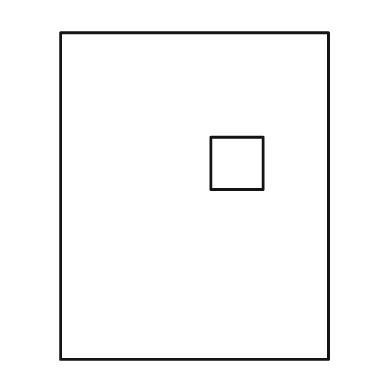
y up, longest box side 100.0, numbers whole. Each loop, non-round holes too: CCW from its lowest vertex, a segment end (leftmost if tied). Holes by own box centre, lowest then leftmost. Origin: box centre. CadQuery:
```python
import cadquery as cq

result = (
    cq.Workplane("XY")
    .moveTo(-41.0, -50.0)
    .lineTo(41.0, -50.0)
    .lineTo(41.0, 50.0)
    .lineTo(-41.0, 50.0)
    .close()
    .moveTo(5.0, 2.0)
    .lineTo(21.0, 2.0)
    .lineTo(21.0, 18.0)
    .lineTo(5.0, 18.0)
    .close()
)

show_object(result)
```